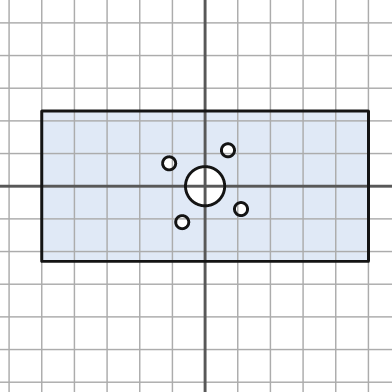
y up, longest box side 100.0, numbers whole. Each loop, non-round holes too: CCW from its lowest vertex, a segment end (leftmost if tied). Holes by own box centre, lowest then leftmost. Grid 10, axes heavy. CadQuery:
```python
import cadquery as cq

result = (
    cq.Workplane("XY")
    .moveTo(-50.0, -23.0)
    .lineTo(50.0, -23.0)
    .lineTo(50.0, 23.0)
    .lineTo(-50.0, 23.0)
    .close()
    .moveTo(-7.0, -11.0)
    .circle(2.0)
    .moveTo(11.0, -7.0)
    .circle(2.0)
    .moveTo(0.0, 0.0)
    .circle(6.0)
    .moveTo(-11.0, 7.0)
    .circle(2.0)
    .moveTo(7.0, 11.0)
    .circle(2.0)
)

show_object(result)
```